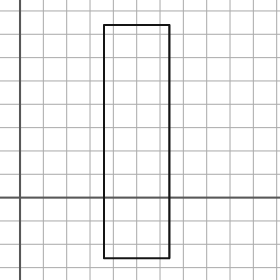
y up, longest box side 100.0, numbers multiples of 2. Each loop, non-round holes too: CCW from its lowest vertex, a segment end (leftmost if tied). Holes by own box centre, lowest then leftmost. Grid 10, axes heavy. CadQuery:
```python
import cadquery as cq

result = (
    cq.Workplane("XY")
    .moveTo(36.0, -26.0)
    .lineTo(64.0, -26.0)
    .lineTo(64.0, 74.0)
    .lineTo(36.0, 74.0)
    .close()
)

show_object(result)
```